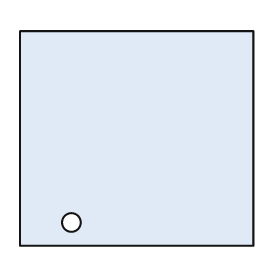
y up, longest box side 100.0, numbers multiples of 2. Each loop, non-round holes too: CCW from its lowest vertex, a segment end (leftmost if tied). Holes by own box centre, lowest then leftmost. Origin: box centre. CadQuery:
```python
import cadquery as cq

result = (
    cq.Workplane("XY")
    .moveTo(-50.0, -46.0)
    .lineTo(50.0, -46.0)
    .lineTo(50.0, 46.0)
    .lineTo(-50.0, 46.0)
    .close()
    .moveTo(-28.0, -36.0)
    .circle(4.0)
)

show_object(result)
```